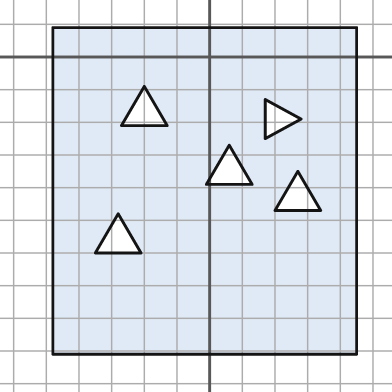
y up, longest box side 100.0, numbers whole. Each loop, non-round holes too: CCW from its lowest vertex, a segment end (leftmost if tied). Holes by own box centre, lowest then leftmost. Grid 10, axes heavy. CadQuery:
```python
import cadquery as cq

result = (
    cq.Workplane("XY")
    .moveTo(-48.0, -91.0)
    .lineTo(45.0, -91.0)
    .lineTo(45.0, 9.0)
    .lineTo(-48.0, 9.0)
    .close()
    .moveTo(-35.0, -60.0)
    .lineTo(-21.0, -60.0)
    .lineTo(-28.0, -48.0)
    .close()
    .moveTo(20.0, -47.0)
    .lineTo(34.0, -47.0)
    .lineTo(27.0, -35.0)
    .close()
    .moveTo(-1.0, -39.0)
    .lineTo(13.0, -39.0)
    .lineTo(6.0, -27.0)
    .close()
    .moveTo(17.0, -25.0)
    .lineTo(28.0, -19.0)
    .lineTo(17.0, -13.0)
    .close()
    .moveTo(-27.0, -21.0)
    .lineTo(-13.0, -21.0)
    .lineTo(-20.0, -9.0)
    .close()
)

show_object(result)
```